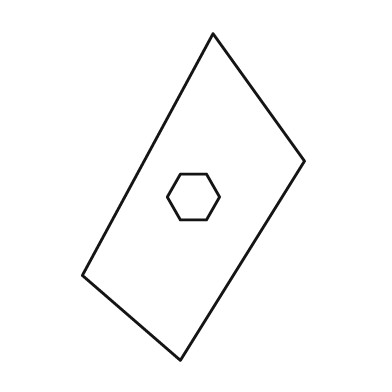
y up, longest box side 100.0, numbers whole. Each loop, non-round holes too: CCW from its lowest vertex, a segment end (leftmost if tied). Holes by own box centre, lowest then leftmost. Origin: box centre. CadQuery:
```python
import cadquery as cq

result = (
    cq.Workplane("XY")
    .moveTo(-4.0, -50.0)
    .lineTo(34.0, 11.0)
    .lineTo(6.0, 50.0)
    .lineTo(-34.0, -24.0)
    .close()
    .moveTo(-4.0, -7.0)
    .lineTo(4.0, -7.0)
    .lineTo(8.0, 0.0)
    .lineTo(4.0, 7.0)
    .lineTo(-4.0, 7.0)
    .lineTo(-8.0, 0.0)
    .close()
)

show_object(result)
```